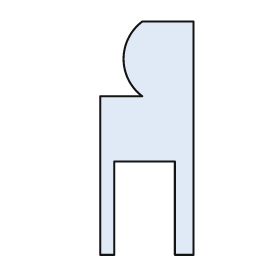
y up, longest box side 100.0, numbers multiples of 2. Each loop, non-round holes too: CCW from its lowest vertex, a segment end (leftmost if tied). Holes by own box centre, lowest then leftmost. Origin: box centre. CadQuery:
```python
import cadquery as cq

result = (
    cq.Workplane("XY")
    .moveTo(-20.0, -50.0)
    .lineTo(-14.0, -50.0)
    .lineTo(-14.0, -10.0)
    .lineTo(12.0, -10.0)
    .lineTo(12.0, -50.0)
    .lineTo(20.0, -50.0)
    .lineTo(20.0, 50.0)
    .lineTo(-2.0, 50.0)
    .threePointArc((-10.0, 34.0), (-2.0, 18.0))
    .lineTo(-20.0, 18.0)
    .close()
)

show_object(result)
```